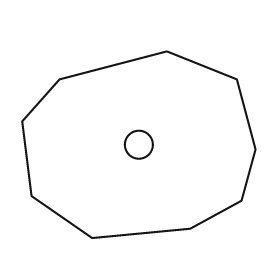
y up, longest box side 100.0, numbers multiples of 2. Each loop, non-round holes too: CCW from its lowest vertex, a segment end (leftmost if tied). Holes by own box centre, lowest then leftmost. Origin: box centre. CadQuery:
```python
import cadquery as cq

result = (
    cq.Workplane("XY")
    .moveTo(-20.0, -40.0)
    .lineTo(22.0, -36.0)
    .lineTo(44.0, -24.0)
    .lineTo(50.0, -2.0)
    .lineTo(42.0, 28.0)
    .lineTo(12.0, 40.0)
    .lineTo(-34.0, 28.0)
    .lineTo(-50.0, 10.0)
    .lineTo(-46.0, -22.0)
    .close()
    .moveTo(0.0, 0.0)
    .circle(6.0)
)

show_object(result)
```